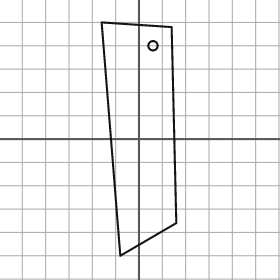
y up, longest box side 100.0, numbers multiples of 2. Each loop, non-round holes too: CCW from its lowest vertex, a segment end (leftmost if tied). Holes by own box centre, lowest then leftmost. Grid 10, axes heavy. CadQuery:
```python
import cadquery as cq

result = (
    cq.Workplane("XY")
    .moveTo(-8.0, -50.0)
    .lineTo(16.0, -36.0)
    .lineTo(14.0, 48.0)
    .lineTo(-16.0, 50.0)
    .close()
    .moveTo(6.0, 40.0)
    .circle(2.0)
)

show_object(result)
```